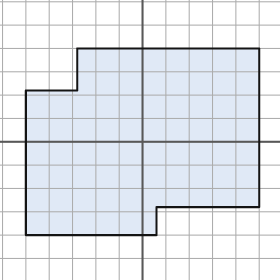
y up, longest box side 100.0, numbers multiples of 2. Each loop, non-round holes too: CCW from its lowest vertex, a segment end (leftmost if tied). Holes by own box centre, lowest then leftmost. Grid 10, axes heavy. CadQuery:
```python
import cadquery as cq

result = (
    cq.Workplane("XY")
    .moveTo(-50.0, -40.0)
    .lineTo(6.0, -40.0)
    .lineTo(6.0, -28.0)
    .lineTo(50.0, -28.0)
    .lineTo(50.0, 40.0)
    .lineTo(-28.0, 40.0)
    .lineTo(-28.0, 22.0)
    .lineTo(-50.0, 22.0)
    .close()
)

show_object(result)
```